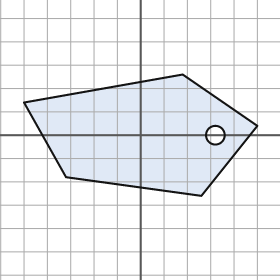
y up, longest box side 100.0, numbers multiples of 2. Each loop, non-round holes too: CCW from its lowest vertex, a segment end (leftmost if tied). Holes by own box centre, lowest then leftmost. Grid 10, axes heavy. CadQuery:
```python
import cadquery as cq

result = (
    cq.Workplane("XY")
    .moveTo(26.0, -26.0)
    .lineTo(50.0, 4.0)
    .lineTo(18.0, 26.0)
    .lineTo(-50.0, 14.0)
    .lineTo(-32.0, -18.0)
    .close()
    .moveTo(32.0, 0.0)
    .circle(4.0)
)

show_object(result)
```